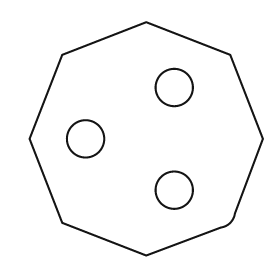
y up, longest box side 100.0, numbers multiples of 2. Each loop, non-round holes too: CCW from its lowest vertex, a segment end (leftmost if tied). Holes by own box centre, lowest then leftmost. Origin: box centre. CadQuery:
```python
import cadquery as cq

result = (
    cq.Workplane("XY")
    .moveTo(0.0, -50.0)
    .lineTo(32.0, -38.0)
    .threePointArc((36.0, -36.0), (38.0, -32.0))
    .lineTo(50.0, 0.0)
    .lineTo(36.0, 36.0)
    .lineTo(0.0, 50.0)
    .lineTo(-36.0, 36.0)
    .lineTo(-50.0, 0.0)
    .lineTo(-36.0, -36.0)
    .close()
    .moveTo(12.0, -22.0)
    .circle(8.0)
    .moveTo(-26.0, 0.0)
    .circle(8.0)
    .moveTo(12.0, 22.0)
    .circle(8.0)
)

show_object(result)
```